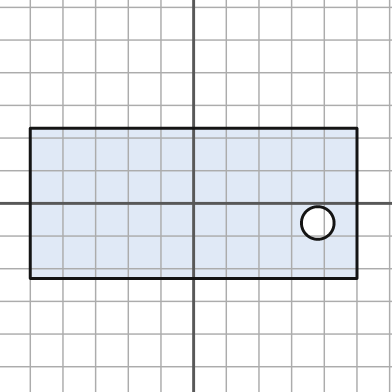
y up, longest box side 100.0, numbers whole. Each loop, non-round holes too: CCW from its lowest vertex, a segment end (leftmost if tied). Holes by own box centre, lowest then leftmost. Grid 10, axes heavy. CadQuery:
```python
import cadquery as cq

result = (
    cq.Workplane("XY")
    .moveTo(-50.0, -23.0)
    .lineTo(50.0, -23.0)
    .lineTo(50.0, 23.0)
    .lineTo(-50.0, 23.0)
    .close()
    .moveTo(38.0, -6.0)
    .circle(5.0)
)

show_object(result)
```